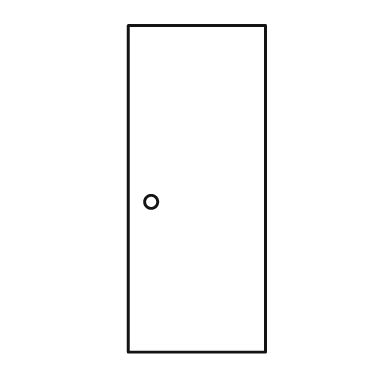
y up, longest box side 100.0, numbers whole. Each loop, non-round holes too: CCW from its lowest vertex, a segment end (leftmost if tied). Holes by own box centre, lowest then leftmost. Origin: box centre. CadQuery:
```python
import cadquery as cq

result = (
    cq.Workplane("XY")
    .moveTo(-21.0, -50.0)
    .lineTo(21.0, -50.0)
    .lineTo(21.0, 50.0)
    .lineTo(-21.0, 50.0)
    .close()
    .moveTo(-14.0, -4.0)
    .circle(2.0)
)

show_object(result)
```